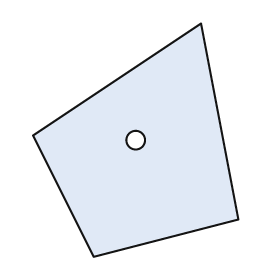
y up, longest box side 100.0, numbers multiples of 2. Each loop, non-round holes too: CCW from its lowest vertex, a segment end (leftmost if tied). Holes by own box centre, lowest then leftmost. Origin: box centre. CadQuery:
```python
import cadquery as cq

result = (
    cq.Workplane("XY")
    .moveTo(-18.0, -50.0)
    .lineTo(44.0, -34.0)
    .lineTo(28.0, 50.0)
    .lineTo(-44.0, 2.0)
    .close()
    .moveTo(0.0, 0.0)
    .circle(4.0)
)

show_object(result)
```